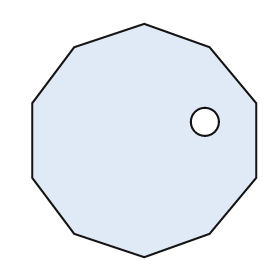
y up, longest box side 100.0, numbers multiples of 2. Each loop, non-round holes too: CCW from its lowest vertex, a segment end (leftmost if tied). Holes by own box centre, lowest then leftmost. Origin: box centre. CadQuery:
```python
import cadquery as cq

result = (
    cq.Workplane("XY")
    .moveTo(0.0, -50.0)
    .lineTo(28.0, -40.0)
    .lineTo(48.0, -16.0)
    .lineTo(48.0, 16.0)
    .lineTo(28.0, 40.0)
    .lineTo(0.0, 50.0)
    .lineTo(-30.0, 40.0)
    .lineTo(-48.0, 16.0)
    .lineTo(-48.0, -16.0)
    .lineTo(-30.0, -40.0)
    .close()
    .moveTo(26.0, 8.0)
    .circle(6.0)
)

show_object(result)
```